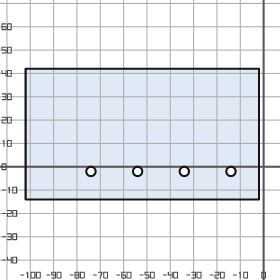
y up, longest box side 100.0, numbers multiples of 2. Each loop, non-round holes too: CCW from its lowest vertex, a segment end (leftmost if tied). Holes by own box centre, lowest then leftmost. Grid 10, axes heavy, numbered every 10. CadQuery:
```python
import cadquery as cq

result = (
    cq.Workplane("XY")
    .moveTo(-102.0, -14.0)
    .lineTo(-2.0, -14.0)
    .lineTo(-2.0, 42.0)
    .lineTo(-102.0, 42.0)
    .close()
    .moveTo(-74.0, -2.0)
    .circle(2.0)
    .moveTo(-54.0, -2.0)
    .circle(2.0)
    .moveTo(-34.0, -2.0)
    .circle(2.0)
    .moveTo(-14.0, -2.0)
    .circle(2.0)
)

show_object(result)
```